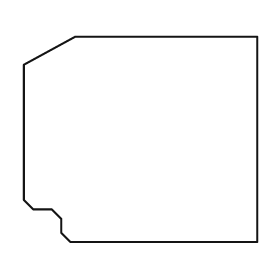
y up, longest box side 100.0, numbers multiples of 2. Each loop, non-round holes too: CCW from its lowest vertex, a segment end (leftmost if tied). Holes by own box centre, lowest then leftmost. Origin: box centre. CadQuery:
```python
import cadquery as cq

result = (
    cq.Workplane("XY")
    .moveTo(-30.0, -44.0)
    .lineTo(50.0, -44.0)
    .lineTo(50.0, 44.0)
    .lineTo(-28.0, 44.0)
    .lineTo(-50.0, 32.0)
    .lineTo(-50.0, -26.0)
    .lineTo(-46.0, -30.0)
    .lineTo(-38.0, -30.0)
    .lineTo(-34.0, -34.0)
    .lineTo(-34.0, -40.0)
    .close()
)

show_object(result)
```